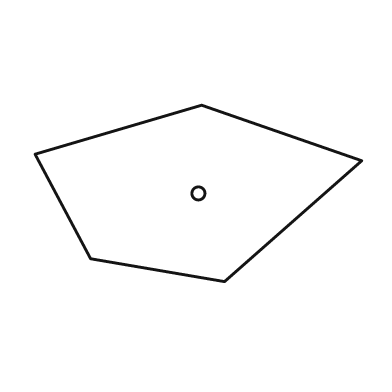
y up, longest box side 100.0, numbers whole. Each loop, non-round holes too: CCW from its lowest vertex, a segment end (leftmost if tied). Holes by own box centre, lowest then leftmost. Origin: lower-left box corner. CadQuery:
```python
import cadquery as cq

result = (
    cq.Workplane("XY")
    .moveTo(58.0, 0.0)
    .lineTo(100.0, 37.0)
    .lineTo(51.0, 54.0)
    .lineTo(0.0, 39.0)
    .lineTo(17.0, 7.0)
    .close()
    .moveTo(50.0, 27.0)
    .circle(2.0)
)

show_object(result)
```